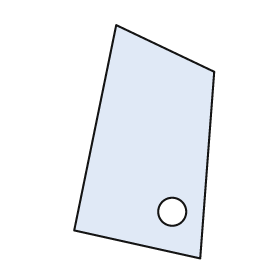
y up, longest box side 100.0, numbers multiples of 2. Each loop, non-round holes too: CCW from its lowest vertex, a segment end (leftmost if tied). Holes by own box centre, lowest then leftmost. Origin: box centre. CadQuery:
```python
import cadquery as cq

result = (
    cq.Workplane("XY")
    .moveTo(24.0, -50.0)
    .lineTo(30.0, 30.0)
    .lineTo(-12.0, 50.0)
    .lineTo(-30.0, -38.0)
    .close()
    .moveTo(12.0, -30.0)
    .circle(6.0)
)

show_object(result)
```